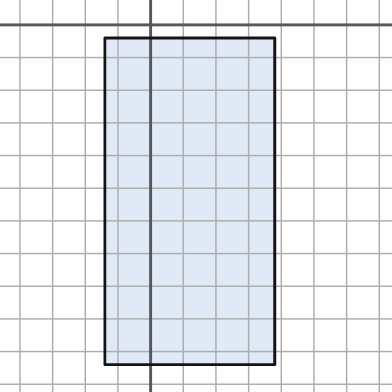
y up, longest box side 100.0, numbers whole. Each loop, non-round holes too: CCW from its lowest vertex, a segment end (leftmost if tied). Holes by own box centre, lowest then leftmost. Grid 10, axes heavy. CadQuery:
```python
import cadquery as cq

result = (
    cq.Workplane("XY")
    .moveTo(-14.0, -104.0)
    .lineTo(38.0, -104.0)
    .lineTo(38.0, -4.0)
    .lineTo(-14.0, -4.0)
    .close()
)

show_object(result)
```